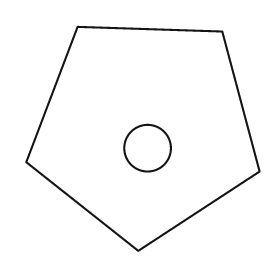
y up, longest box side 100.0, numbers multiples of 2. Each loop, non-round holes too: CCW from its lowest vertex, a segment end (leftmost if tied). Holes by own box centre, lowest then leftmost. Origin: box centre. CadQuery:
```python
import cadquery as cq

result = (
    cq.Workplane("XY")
    .moveTo(-2.0, -48.0)
    .lineTo(50.0, -14.0)
    .lineTo(34.0, 46.0)
    .lineTo(-28.0, 48.0)
    .lineTo(-50.0, -10.0)
    .close()
    .moveTo(2.0, -4.0)
    .circle(10.0)
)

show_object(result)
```